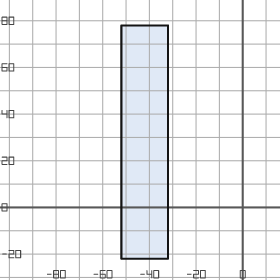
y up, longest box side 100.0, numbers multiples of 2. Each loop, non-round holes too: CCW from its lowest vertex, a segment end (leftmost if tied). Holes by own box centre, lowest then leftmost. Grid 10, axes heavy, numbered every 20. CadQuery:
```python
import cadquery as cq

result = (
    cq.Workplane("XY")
    .moveTo(-52.0, -22.0)
    .lineTo(-32.0, -22.0)
    .lineTo(-32.0, 78.0)
    .lineTo(-52.0, 78.0)
    .close()
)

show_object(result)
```